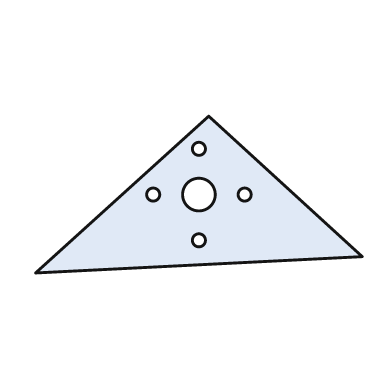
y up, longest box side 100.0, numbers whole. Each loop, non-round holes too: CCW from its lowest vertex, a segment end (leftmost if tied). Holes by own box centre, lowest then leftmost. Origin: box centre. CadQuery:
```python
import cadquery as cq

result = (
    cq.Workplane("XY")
    .moveTo(-50.0, -24.0)
    .lineTo(50.0, -19.0)
    .lineTo(3.0, 24.0)
    .close()
    .moveTo(0.0, -14.0)
    .circle(2.0)
    .moveTo(-14.0, 0.0)
    .circle(2.0)
    .moveTo(0.0, 0.0)
    .circle(5.0)
    .moveTo(14.0, 0.0)
    .circle(2.0)
    .moveTo(0.0, 14.0)
    .circle(2.0)
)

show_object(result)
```